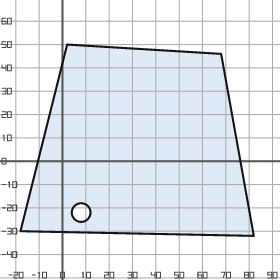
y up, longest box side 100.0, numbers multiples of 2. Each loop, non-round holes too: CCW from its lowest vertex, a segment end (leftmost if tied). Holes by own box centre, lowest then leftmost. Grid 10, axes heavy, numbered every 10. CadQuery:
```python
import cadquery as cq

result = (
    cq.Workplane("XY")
    .moveTo(82.0, -32.0)
    .lineTo(68.0, 46.0)
    .lineTo(2.0, 50.0)
    .lineTo(-18.0, -30.0)
    .close()
    .moveTo(8.0, -22.0)
    .circle(4.0)
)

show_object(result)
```